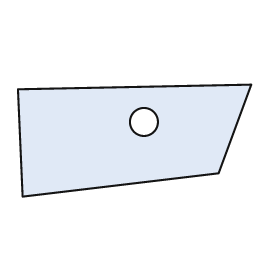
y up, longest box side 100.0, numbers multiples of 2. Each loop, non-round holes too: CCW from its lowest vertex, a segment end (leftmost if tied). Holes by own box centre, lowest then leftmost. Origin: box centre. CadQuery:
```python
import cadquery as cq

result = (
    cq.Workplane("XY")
    .moveTo(-48.0, -24.0)
    .lineTo(36.0, -14.0)
    .lineTo(50.0, 24.0)
    .lineTo(-50.0, 22.0)
    .close()
    .moveTo(4.0, 8.0)
    .circle(6.0)
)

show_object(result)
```